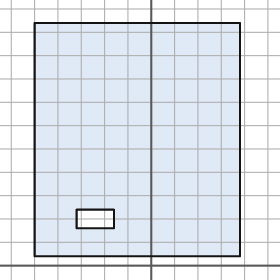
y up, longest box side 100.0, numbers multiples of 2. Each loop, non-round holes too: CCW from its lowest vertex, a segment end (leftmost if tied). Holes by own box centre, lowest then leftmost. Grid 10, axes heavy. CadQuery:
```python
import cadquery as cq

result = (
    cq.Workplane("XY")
    .moveTo(-50.0, 4.0)
    .lineTo(38.0, 4.0)
    .lineTo(38.0, 104.0)
    .lineTo(-50.0, 104.0)
    .close()
    .moveTo(-32.0, 16.0)
    .lineTo(-16.0, 16.0)
    .lineTo(-16.0, 24.0)
    .lineTo(-32.0, 24.0)
    .close()
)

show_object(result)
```